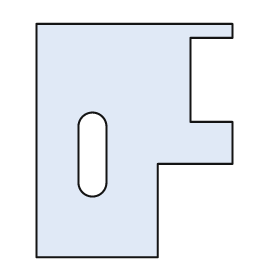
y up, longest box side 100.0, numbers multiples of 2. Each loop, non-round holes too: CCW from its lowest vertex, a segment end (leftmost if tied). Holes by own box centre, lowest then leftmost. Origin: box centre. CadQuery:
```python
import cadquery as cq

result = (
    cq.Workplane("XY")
    .moveTo(-42.0, -50.0)
    .lineTo(10.0, -50.0)
    .lineTo(10.0, -10.0)
    .lineTo(42.0, -10.0)
    .lineTo(42.0, 8.0)
    .lineTo(24.0, 8.0)
    .lineTo(24.0, 44.0)
    .lineTo(42.0, 44.0)
    .lineTo(42.0, 50.0)
    .lineTo(-42.0, 50.0)
    .close()
    .moveTo(-24.0, -18.0)
    .threePointArc((-18.0, -24.0), (-12.0, -18.0))
    .lineTo(-12.0, 6.0)
    .threePointArc((-18.0, 12.0), (-24.0, 6.0))
    .close()
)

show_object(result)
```